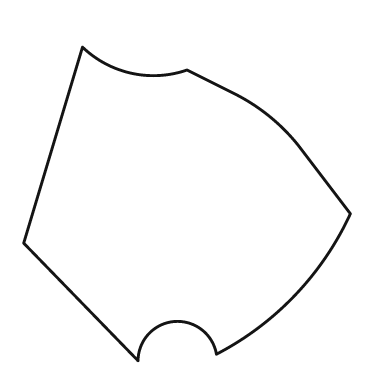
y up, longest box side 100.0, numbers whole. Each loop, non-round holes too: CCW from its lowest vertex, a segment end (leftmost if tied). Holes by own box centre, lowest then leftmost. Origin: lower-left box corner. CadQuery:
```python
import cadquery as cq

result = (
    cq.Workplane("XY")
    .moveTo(35.0, 0.0)
    .threePointArc((46.0, 12.0), (59.0, 2.0))
    .threePointArc((83.0, 20.0), (100.0, 45.0))
    .lineTo(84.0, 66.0)
    .threePointArc((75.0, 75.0), (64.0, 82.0))
    .lineTo(50.0, 89.0)
    .threePointArc((33.0, 88.0), (18.0, 96.0))
    .lineTo(0.0, 36.0)
    .close()
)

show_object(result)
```